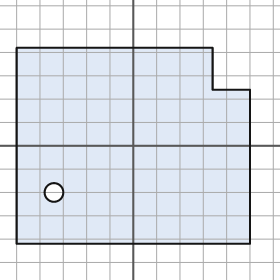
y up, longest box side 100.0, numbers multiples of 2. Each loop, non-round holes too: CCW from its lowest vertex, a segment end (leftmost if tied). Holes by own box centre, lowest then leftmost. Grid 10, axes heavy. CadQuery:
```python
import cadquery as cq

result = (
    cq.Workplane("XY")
    .moveTo(-50.0, -42.0)
    .lineTo(50.0, -42.0)
    .lineTo(50.0, 24.0)
    .lineTo(34.0, 24.0)
    .lineTo(34.0, 42.0)
    .lineTo(-50.0, 42.0)
    .close()
    .moveTo(-34.0, -20.0)
    .circle(4.0)
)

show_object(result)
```